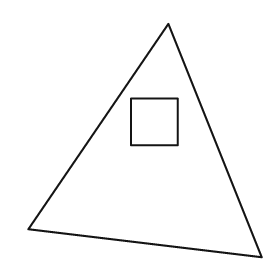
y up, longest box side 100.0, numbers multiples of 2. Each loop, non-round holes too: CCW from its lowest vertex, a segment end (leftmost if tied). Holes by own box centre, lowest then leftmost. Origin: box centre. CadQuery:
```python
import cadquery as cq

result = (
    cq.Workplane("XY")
    .moveTo(50.0, -50.0)
    .lineTo(10.0, 50.0)
    .lineTo(-50.0, -38.0)
    .close()
    .moveTo(-6.0, -2.0)
    .lineTo(14.0, -2.0)
    .lineTo(14.0, 18.0)
    .lineTo(-6.0, 18.0)
    .close()
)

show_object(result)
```